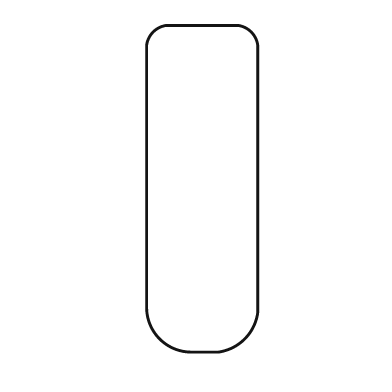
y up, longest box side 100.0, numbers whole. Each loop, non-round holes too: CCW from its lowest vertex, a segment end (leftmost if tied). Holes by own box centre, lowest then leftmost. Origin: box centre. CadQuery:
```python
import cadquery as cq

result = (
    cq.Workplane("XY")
    .moveTo(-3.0, -50.0)
    .lineTo(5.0, -50.0)
    .threePointArc((13.0, -46.0), (17.0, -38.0))
    .lineTo(17.0, 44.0)
    .threePointArc((15.0, 48.0), (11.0, 50.0))
    .lineTo(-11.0, 50.0)
    .threePointArc((-15.0, 48.0), (-17.0, 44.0))
    .lineTo(-17.0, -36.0)
    .threePointArc((-13.0, -46.0), (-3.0, -50.0))
    .close()
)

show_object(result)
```